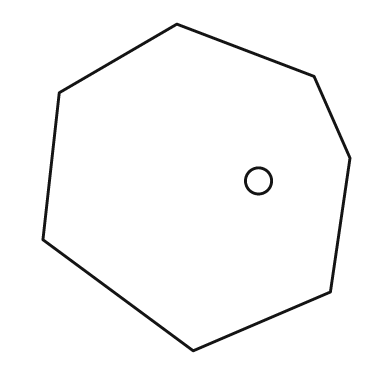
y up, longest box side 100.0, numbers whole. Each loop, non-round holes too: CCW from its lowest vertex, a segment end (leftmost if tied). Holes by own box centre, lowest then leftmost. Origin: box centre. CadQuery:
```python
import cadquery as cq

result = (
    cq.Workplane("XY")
    .moveTo(-1.0, -50.0)
    .lineTo(41.0, -32.0)
    .lineTo(47.0, 9.0)
    .lineTo(36.0, 34.0)
    .lineTo(-6.0, 50.0)
    .lineTo(-42.0, 29.0)
    .lineTo(-47.0, -16.0)
    .close()
    .moveTo(19.0, 2.0)
    .circle(4.0)
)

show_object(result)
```